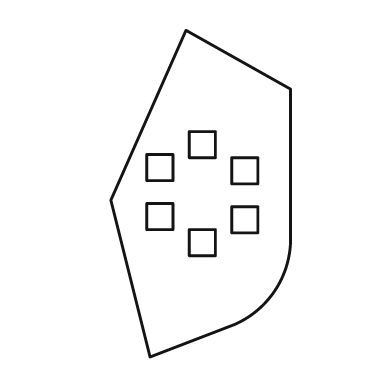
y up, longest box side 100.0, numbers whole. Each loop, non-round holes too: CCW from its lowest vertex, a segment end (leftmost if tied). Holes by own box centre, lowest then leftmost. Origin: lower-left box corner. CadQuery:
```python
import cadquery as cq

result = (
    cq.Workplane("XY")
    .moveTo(12.0, 0.0)
    .lineTo(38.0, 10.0)
    .threePointArc((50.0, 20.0), (55.0, 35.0))
    .lineTo(55.0, 82.0)
    .lineTo(23.0, 100.0)
    .lineTo(0.0, 48.0)
    .close()
    .moveTo(24.0, 31.0)
    .lineTo(32.0, 31.0)
    .lineTo(32.0, 39.0)
    .lineTo(24.0, 39.0)
    .close()
    .moveTo(37.0, 38.0)
    .lineTo(45.0, 38.0)
    .lineTo(45.0, 46.0)
    .lineTo(37.0, 46.0)
    .close()
    .moveTo(11.0, 39.0)
    .lineTo(19.0, 39.0)
    .lineTo(19.0, 47.0)
    .lineTo(11.0, 47.0)
    .close()
    .moveTo(37.0, 53.0)
    .lineTo(45.0, 53.0)
    .lineTo(45.0, 61.0)
    .lineTo(37.0, 61.0)
    .close()
    .moveTo(11.0, 54.0)
    .lineTo(19.0, 54.0)
    .lineTo(19.0, 62.0)
    .lineTo(11.0, 62.0)
    .close()
    .moveTo(24.0, 61.0)
    .lineTo(32.0, 61.0)
    .lineTo(32.0, 69.0)
    .lineTo(24.0, 69.0)
    .close()
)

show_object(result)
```